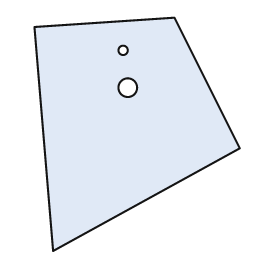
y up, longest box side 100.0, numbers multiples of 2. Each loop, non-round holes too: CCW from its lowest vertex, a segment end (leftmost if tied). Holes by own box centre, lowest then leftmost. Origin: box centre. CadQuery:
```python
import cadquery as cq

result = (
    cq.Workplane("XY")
    .moveTo(-36.0, -50.0)
    .lineTo(44.0, -6.0)
    .lineTo(16.0, 50.0)
    .lineTo(-44.0, 46.0)
    .close()
    .moveTo(-4.0, 20.0)
    .circle(4.0)
    .moveTo(-6.0, 36.0)
    .circle(2.0)
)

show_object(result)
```